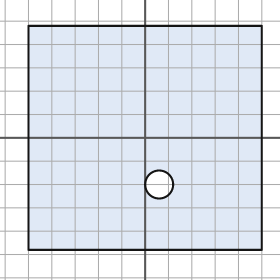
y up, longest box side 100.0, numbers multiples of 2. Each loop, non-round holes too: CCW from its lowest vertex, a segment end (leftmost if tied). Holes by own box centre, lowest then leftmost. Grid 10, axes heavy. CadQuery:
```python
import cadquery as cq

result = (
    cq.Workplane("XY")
    .moveTo(-50.0, -48.0)
    .lineTo(50.0, -48.0)
    .lineTo(50.0, 48.0)
    .lineTo(-50.0, 48.0)
    .close()
    .moveTo(6.0, -20.0)
    .circle(6.0)
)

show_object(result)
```